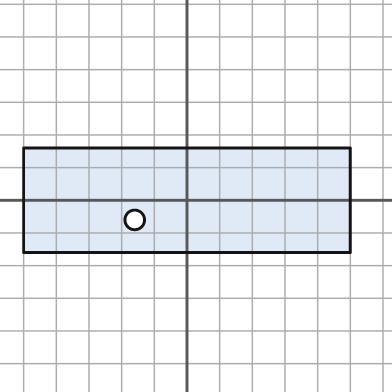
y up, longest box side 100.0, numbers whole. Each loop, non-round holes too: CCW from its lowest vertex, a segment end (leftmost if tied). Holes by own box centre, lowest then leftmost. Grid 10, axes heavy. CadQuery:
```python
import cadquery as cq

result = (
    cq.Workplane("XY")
    .moveTo(-50.0, -16.0)
    .lineTo(50.0, -16.0)
    .lineTo(50.0, 16.0)
    .lineTo(-50.0, 16.0)
    .close()
    .moveTo(-16.0, -6.0)
    .circle(3.0)
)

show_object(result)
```